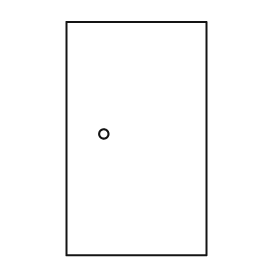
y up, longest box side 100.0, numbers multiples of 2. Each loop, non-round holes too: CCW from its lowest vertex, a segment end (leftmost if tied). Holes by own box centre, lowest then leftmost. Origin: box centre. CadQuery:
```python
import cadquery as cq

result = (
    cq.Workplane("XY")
    .moveTo(-30.0, -50.0)
    .lineTo(30.0, -50.0)
    .lineTo(30.0, 50.0)
    .lineTo(-30.0, 50.0)
    .close()
    .moveTo(-14.0, 2.0)
    .circle(2.0)
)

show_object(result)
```